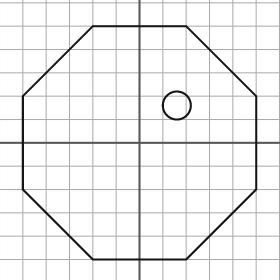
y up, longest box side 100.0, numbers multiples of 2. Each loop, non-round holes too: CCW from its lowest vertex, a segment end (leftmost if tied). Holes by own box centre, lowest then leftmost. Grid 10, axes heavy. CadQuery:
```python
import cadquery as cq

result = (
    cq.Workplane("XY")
    .moveTo(-20.0, -50.0)
    .lineTo(20.0, -50.0)
    .lineTo(50.0, -20.0)
    .lineTo(50.0, 20.0)
    .lineTo(20.0, 50.0)
    .lineTo(-20.0, 50.0)
    .lineTo(-50.0, 20.0)
    .lineTo(-50.0, -20.0)
    .close()
    .moveTo(16.0, 16.0)
    .circle(6.0)
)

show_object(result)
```